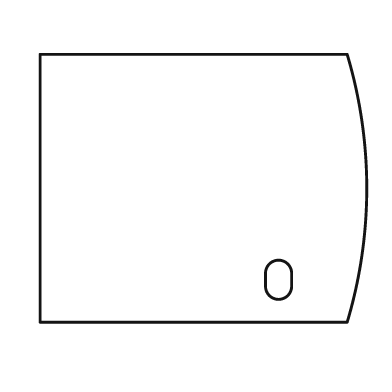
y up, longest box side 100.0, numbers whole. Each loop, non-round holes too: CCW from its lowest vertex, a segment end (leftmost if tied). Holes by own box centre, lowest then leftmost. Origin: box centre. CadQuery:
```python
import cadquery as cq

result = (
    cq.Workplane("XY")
    .moveTo(-50.0, -41.0)
    .lineTo(44.0, -41.0)
    .threePointArc((50.0, 0.0), (44.0, 41.0))
    .lineTo(-50.0, 41.0)
    .close()
    .moveTo(19.0, -30.0)
    .threePointArc((23.0, -34.0), (27.0, -30.0))
    .lineTo(27.0, -26.0)
    .threePointArc((23.0, -22.0), (19.0, -26.0))
    .close()
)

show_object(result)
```